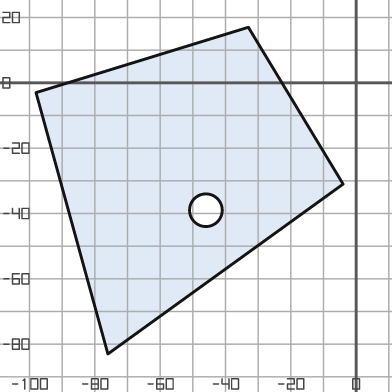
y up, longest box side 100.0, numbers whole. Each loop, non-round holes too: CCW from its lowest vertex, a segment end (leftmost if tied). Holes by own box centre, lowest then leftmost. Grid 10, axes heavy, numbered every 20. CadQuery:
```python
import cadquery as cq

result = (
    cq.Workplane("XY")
    .moveTo(-76.0, -83.0)
    .lineTo(-4.0, -31.0)
    .lineTo(-33.0, 17.0)
    .lineTo(-98.0, -3.0)
    .close()
    .moveTo(-46.0, -39.0)
    .circle(5.0)
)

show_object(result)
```